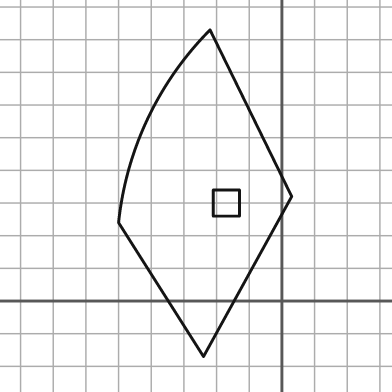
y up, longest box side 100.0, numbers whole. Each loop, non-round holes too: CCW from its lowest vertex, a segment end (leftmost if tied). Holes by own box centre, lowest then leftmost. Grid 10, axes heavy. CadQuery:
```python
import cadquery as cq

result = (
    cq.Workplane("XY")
    .moveTo(-24.0, -17.0)
    .lineTo(3.0, 32.0)
    .lineTo(-22.0, 83.0)
    .threePointArc((-41.0, 56.0), (-50.0, 24.0))
    .close()
    .moveTo(-21.0, 26.0)
    .lineTo(-13.0, 26.0)
    .lineTo(-13.0, 34.0)
    .lineTo(-21.0, 34.0)
    .close()
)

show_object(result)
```